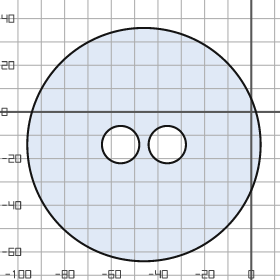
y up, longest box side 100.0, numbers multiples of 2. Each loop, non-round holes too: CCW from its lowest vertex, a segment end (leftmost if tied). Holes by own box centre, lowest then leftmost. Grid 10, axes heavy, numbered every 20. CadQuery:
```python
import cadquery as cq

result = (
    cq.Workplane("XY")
    .moveTo(-46.0, -14.0)
    .circle(50.0)
    .moveTo(-56.0, -14.0)
    .circle(8.0)
    .moveTo(-36.0, -14.0)
    .circle(8.0)
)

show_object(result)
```